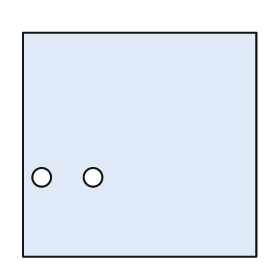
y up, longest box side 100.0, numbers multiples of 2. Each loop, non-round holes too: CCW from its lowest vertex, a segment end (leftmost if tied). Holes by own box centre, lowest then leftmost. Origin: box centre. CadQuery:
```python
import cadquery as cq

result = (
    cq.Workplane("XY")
    .moveTo(-50.0, -48.0)
    .lineTo(50.0, -48.0)
    .lineTo(50.0, 48.0)
    .lineTo(-50.0, 48.0)
    .close()
    .moveTo(-42.0, -14.0)
    .circle(4.0)
    .moveTo(-20.0, -14.0)
    .circle(4.0)
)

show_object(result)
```